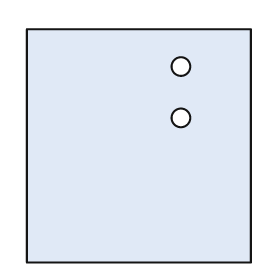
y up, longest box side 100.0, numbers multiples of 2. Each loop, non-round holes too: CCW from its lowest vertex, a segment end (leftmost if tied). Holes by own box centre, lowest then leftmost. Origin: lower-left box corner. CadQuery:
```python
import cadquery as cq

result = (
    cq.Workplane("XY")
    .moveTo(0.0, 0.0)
    .lineTo(96.0, 0.0)
    .lineTo(96.0, 100.0)
    .lineTo(0.0, 100.0)
    .close()
    .moveTo(66.0, 62.0)
    .circle(4.0)
    .moveTo(66.0, 84.0)
    .circle(4.0)
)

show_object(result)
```